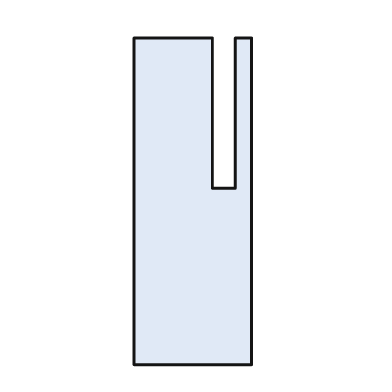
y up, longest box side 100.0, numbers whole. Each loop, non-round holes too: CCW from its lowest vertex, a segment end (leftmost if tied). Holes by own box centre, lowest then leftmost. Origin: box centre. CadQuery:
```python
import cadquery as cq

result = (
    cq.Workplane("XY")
    .moveTo(-18.0, -50.0)
    .lineTo(18.0, -50.0)
    .lineTo(18.0, 50.0)
    .lineTo(13.0, 50.0)
    .lineTo(13.0, 4.0)
    .lineTo(6.0, 4.0)
    .lineTo(6.0, 50.0)
    .lineTo(-18.0, 50.0)
    .close()
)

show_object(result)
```